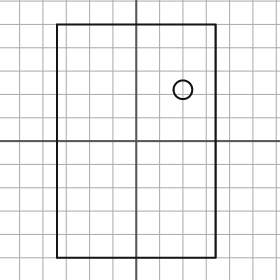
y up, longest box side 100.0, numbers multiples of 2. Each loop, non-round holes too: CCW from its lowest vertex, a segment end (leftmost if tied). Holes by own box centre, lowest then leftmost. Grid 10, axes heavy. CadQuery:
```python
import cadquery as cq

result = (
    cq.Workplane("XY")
    .moveTo(-34.0, -50.0)
    .lineTo(34.0, -50.0)
    .lineTo(34.0, 50.0)
    .lineTo(-34.0, 50.0)
    .close()
    .moveTo(20.0, 22.0)
    .circle(4.0)
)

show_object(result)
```